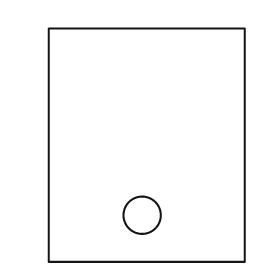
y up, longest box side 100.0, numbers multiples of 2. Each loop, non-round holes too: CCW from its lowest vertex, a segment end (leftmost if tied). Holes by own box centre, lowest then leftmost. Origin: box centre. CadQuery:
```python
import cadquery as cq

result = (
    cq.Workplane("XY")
    .moveTo(-42.0, -50.0)
    .lineTo(42.0, -50.0)
    .lineTo(42.0, 50.0)
    .lineTo(-42.0, 50.0)
    .close()
    .moveTo(-2.0, -30.0)
    .circle(8.0)
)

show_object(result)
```